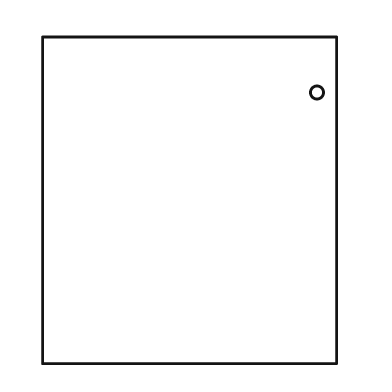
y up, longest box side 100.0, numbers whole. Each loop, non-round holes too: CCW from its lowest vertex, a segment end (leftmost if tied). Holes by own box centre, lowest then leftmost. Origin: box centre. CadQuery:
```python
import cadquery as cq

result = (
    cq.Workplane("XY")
    .moveTo(-45.0, -50.0)
    .lineTo(45.0, -50.0)
    .lineTo(45.0, 50.0)
    .lineTo(-45.0, 50.0)
    .close()
    .moveTo(39.0, 33.0)
    .circle(2.0)
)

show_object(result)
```